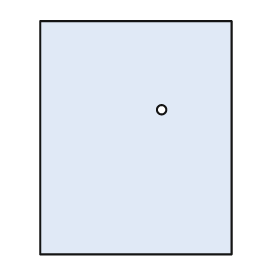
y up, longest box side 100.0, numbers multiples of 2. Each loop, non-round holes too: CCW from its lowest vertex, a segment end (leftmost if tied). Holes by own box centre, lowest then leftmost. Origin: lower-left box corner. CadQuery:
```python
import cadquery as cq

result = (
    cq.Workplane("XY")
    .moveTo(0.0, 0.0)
    .lineTo(82.0, 0.0)
    .lineTo(82.0, 100.0)
    .lineTo(0.0, 100.0)
    .close()
    .moveTo(52.0, 62.0)
    .circle(2.0)
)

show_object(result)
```